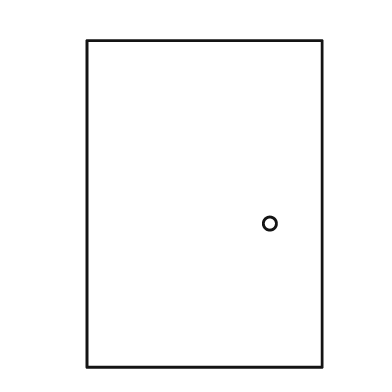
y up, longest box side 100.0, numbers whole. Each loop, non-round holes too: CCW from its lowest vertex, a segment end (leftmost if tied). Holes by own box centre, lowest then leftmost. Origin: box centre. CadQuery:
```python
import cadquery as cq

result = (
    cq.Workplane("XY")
    .moveTo(-36.0, -50.0)
    .lineTo(36.0, -50.0)
    .lineTo(36.0, 50.0)
    .lineTo(-36.0, 50.0)
    .close()
    .moveTo(20.0, -6.0)
    .circle(2.0)
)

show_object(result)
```